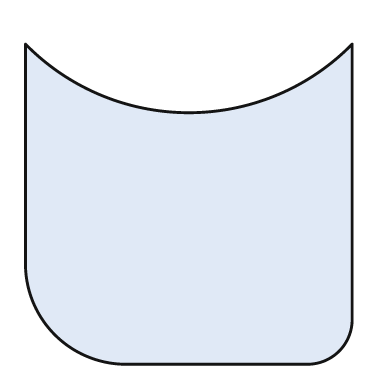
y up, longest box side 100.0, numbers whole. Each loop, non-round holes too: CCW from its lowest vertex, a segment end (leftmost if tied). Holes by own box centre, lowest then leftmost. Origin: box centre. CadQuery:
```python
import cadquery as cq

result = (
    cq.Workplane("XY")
    .moveTo(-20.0, -49.0)
    .lineTo(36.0, -49.0)
    .threePointArc((46.0, -45.0), (50.0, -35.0))
    .lineTo(50.0, 49.0)
    .threePointArc((0.0, 28.0), (-50.0, 49.0))
    .lineTo(-50.0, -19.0)
    .threePointArc((-41.0, -40.0), (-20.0, -49.0))
    .close()
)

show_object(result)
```